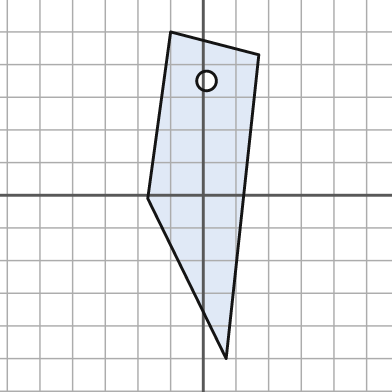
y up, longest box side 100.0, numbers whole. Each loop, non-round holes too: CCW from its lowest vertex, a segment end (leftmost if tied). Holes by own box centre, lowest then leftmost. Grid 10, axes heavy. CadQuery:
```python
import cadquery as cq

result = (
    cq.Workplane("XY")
    .moveTo(7.0, -50.0)
    .lineTo(17.0, 43.0)
    .lineTo(-10.0, 50.0)
    .lineTo(-17.0, -1.0)
    .close()
    .moveTo(1.0, 35.0)
    .circle(3.0)
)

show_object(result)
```